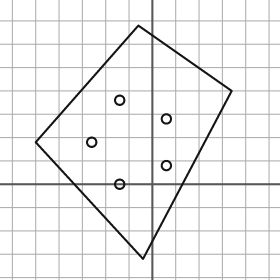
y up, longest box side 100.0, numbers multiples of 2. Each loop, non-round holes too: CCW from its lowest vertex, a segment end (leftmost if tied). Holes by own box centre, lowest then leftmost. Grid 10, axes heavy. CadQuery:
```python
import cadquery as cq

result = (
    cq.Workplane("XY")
    .moveTo(-4.0, -32.0)
    .lineTo(34.0, 40.0)
    .lineTo(-6.0, 68.0)
    .lineTo(-50.0, 18.0)
    .close()
    .moveTo(-14.0, 0.0)
    .circle(2.0)
    .moveTo(6.0, 8.0)
    .circle(2.0)
    .moveTo(-26.0, 18.0)
    .circle(2.0)
    .moveTo(6.0, 28.0)
    .circle(2.0)
    .moveTo(-14.0, 36.0)
    .circle(2.0)
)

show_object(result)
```